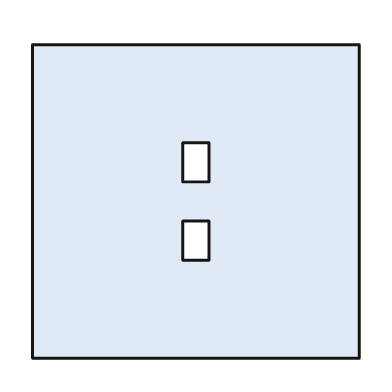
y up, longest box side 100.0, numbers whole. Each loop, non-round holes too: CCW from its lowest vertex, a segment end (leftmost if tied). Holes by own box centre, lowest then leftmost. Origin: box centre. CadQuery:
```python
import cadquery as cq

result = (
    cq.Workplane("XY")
    .moveTo(-50.0, -48.0)
    .lineTo(50.0, -48.0)
    .lineTo(50.0, 48.0)
    .lineTo(-50.0, 48.0)
    .close()
    .moveTo(-4.0, -18.0)
    .lineTo(4.0, -18.0)
    .lineTo(4.0, -6.0)
    .lineTo(-4.0, -6.0)
    .close()
    .moveTo(-4.0, 6.0)
    .lineTo(4.0, 6.0)
    .lineTo(4.0, 18.0)
    .lineTo(-4.0, 18.0)
    .close()
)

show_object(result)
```